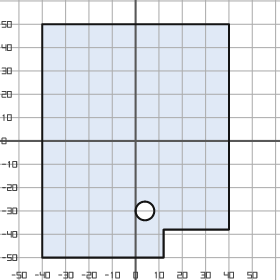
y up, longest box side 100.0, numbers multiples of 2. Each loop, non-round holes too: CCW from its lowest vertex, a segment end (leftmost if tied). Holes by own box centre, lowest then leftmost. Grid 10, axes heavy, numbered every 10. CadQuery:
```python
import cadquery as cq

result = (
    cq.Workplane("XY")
    .moveTo(-40.0, -50.0)
    .lineTo(12.0, -50.0)
    .lineTo(12.0, -38.0)
    .lineTo(40.0, -38.0)
    .lineTo(40.0, 50.0)
    .lineTo(-40.0, 50.0)
    .close()
    .moveTo(4.0, -30.0)
    .circle(4.0)
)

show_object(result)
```